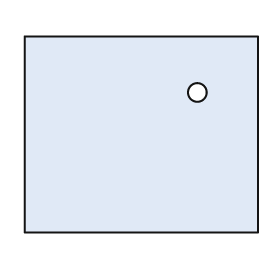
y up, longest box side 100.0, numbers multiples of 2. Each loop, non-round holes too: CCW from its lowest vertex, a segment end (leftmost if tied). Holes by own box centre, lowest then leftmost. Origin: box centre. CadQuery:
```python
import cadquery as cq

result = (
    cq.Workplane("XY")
    .moveTo(-50.0, -42.0)
    .lineTo(50.0, -42.0)
    .lineTo(50.0, 42.0)
    .lineTo(-50.0, 42.0)
    .close()
    .moveTo(24.0, 18.0)
    .circle(4.0)
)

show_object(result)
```